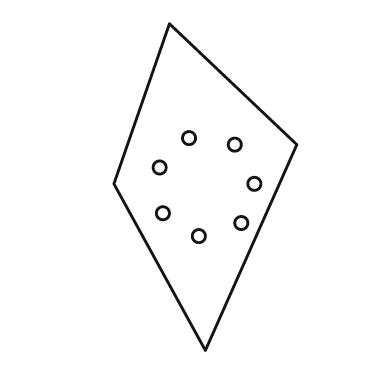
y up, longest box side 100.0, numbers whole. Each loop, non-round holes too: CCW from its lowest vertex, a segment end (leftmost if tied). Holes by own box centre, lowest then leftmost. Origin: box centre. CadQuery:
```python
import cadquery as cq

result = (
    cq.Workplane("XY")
    .moveTo(0.0, -50.0)
    .lineTo(28.0, 13.0)
    .lineTo(-11.0, 50.0)
    .lineTo(-28.0, 1.0)
    .close()
    .moveTo(-2.0, -15.0)
    .circle(2.0)
    .moveTo(11.0, -11.0)
    .circle(2.0)
    .moveTo(-13.0, -8.0)
    .circle(2.0)
    .moveTo(15.0, 1.0)
    .circle(2.0)
    .moveTo(-14.0, 6.0)
    .circle(2.0)
    .moveTo(9.0, 13.0)
    .circle(2.0)
    .moveTo(-5.0, 15.0)
    .circle(2.0)
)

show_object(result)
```